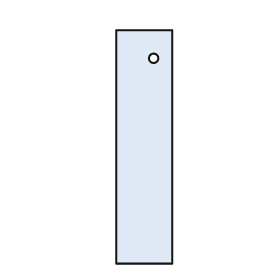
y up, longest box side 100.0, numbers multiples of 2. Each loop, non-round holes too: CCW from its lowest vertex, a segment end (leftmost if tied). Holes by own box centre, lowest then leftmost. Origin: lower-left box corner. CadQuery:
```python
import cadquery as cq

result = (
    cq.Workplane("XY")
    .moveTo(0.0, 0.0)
    .lineTo(24.0, 0.0)
    .lineTo(24.0, 100.0)
    .lineTo(0.0, 100.0)
    .close()
    .moveTo(16.0, 88.0)
    .circle(2.0)
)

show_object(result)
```